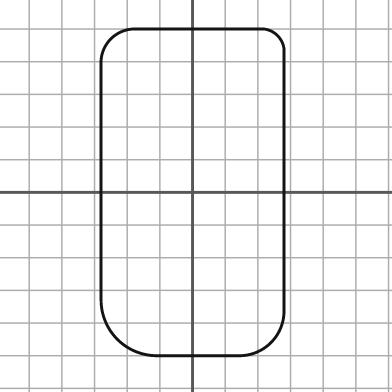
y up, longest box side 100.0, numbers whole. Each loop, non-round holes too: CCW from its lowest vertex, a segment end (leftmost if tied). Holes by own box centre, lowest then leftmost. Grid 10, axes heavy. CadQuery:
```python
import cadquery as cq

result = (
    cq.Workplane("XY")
    .moveTo(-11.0, -50.0)
    .lineTo(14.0, -50.0)
    .threePointArc((24.0, -46.0), (28.0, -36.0))
    .lineTo(28.0, 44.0)
    .threePointArc((26.0, 48.0), (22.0, 50.0))
    .lineTo(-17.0, 50.0)
    .threePointArc((-25.0, 47.0), (-28.0, 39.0))
    .lineTo(-28.0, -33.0)
    .threePointArc((-23.0, -45.0), (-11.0, -50.0))
    .close()
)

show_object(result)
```